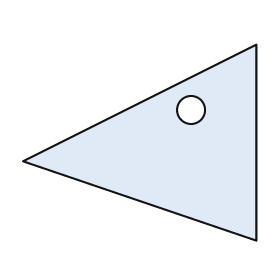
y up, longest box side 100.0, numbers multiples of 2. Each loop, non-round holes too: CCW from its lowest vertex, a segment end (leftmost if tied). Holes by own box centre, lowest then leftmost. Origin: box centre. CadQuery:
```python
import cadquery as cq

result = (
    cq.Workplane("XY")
    .moveTo(50.0, -42.0)
    .lineTo(50.0, 42.0)
    .lineTo(-50.0, -8.0)
    .close()
    .moveTo(22.0, 14.0)
    .circle(6.0)
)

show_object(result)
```